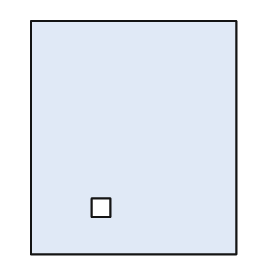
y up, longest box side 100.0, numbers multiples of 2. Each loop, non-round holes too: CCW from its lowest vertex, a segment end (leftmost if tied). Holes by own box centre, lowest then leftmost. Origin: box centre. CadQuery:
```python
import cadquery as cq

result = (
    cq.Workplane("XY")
    .moveTo(-44.0, -50.0)
    .lineTo(44.0, -50.0)
    .lineTo(44.0, 50.0)
    .lineTo(-44.0, 50.0)
    .close()
    .moveTo(-18.0, -34.0)
    .lineTo(-10.0, -34.0)
    .lineTo(-10.0, -26.0)
    .lineTo(-18.0, -26.0)
    .close()
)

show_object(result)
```